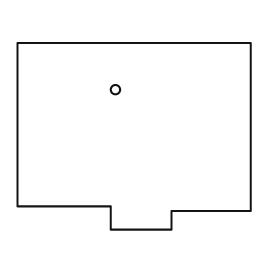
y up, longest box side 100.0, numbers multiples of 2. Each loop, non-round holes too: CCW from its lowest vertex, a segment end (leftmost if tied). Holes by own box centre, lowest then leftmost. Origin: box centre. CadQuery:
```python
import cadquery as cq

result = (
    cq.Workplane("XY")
    .moveTo(-10.0, -40.0)
    .lineTo(16.0, -40.0)
    .lineTo(16.0, -32.0)
    .lineTo(50.0, -32.0)
    .lineTo(50.0, 40.0)
    .lineTo(-50.0, 40.0)
    .lineTo(-50.0, -30.0)
    .lineTo(-10.0, -30.0)
    .close()
    .moveTo(-8.0, 20.0)
    .circle(2.0)
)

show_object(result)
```